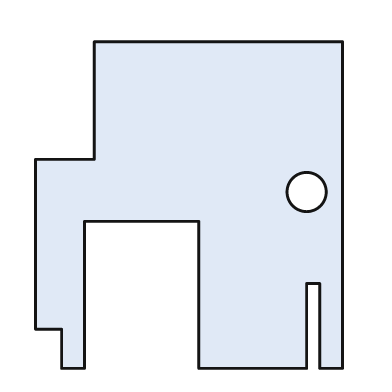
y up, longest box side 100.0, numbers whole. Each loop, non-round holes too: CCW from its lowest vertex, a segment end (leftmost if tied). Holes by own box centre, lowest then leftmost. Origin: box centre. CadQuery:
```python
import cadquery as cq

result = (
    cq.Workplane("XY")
    .moveTo(-39.0, -50.0)
    .lineTo(-32.0, -50.0)
    .lineTo(-32.0, -5.0)
    .lineTo(3.0, -5.0)
    .lineTo(3.0, -50.0)
    .lineTo(36.0, -50.0)
    .lineTo(36.0, -24.0)
    .lineTo(40.0, -24.0)
    .lineTo(40.0, -50.0)
    .lineTo(47.0, -50.0)
    .lineTo(47.0, 50.0)
    .lineTo(-29.0, 50.0)
    .lineTo(-29.0, 14.0)
    .lineTo(-47.0, 14.0)
    .lineTo(-47.0, -38.0)
    .lineTo(-39.0, -38.0)
    .close()
    .moveTo(36.0, 4.0)
    .circle(6.0)
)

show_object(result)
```